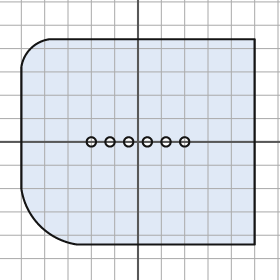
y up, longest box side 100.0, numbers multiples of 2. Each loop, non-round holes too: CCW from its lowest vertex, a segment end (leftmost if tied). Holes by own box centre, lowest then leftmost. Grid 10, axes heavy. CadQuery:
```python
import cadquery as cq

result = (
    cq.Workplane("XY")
    .moveTo(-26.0, -44.0)
    .lineTo(50.0, -44.0)
    .lineTo(50.0, 44.0)
    .lineTo(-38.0, 44.0)
    .threePointArc((-46.0, 40.0), (-50.0, 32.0))
    .lineTo(-50.0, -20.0)
    .threePointArc((-42.0, -36.0), (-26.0, -44.0))
    .close()
    .moveTo(-20.0, 0.0)
    .circle(2.0)
    .moveTo(-12.0, 0.0)
    .circle(2.0)
    .moveTo(-4.0, 0.0)
    .circle(2.0)
    .moveTo(4.0, 0.0)
    .circle(2.0)
    .moveTo(12.0, 0.0)
    .circle(2.0)
    .moveTo(20.0, 0.0)
    .circle(2.0)
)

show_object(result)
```